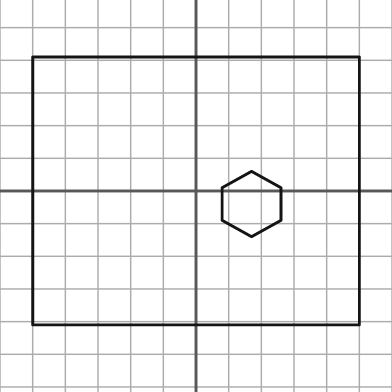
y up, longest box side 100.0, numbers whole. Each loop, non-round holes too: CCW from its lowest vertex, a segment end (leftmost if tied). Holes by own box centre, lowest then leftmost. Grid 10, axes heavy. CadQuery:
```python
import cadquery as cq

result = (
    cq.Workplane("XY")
    .moveTo(-50.0, -41.0)
    .lineTo(50.0, -41.0)
    .lineTo(50.0, 41.0)
    .lineTo(-50.0, 41.0)
    .close()
    .moveTo(17.0, -14.0)
    .lineTo(26.0, -9.0)
    .lineTo(26.0, 1.0)
    .lineTo(17.0, 6.0)
    .lineTo(8.0, 1.0)
    .lineTo(8.0, -9.0)
    .close()
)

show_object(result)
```